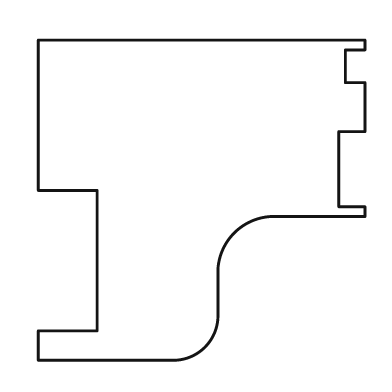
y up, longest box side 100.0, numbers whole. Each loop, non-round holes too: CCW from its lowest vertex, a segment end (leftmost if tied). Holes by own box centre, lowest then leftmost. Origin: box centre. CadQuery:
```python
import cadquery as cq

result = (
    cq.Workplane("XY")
    .moveTo(-50.0, -49.0)
    .lineTo(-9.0, -49.0)
    .threePointArc((1.0, -45.0), (5.0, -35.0))
    .lineTo(5.0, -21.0)
    .threePointArc((10.0, -10.0), (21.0, -5.0))
    .lineTo(50.0, -5.0)
    .lineTo(50.0, -2.0)
    .lineTo(42.0, -2.0)
    .lineTo(42.0, 21.0)
    .lineTo(50.0, 21.0)
    .lineTo(50.0, 36.0)
    .lineTo(44.0, 36.0)
    .lineTo(44.0, 46.0)
    .lineTo(50.0, 46.0)
    .lineTo(50.0, 49.0)
    .lineTo(-50.0, 49.0)
    .lineTo(-50.0, 3.0)
    .lineTo(-32.0, 3.0)
    .lineTo(-32.0, -40.0)
    .lineTo(-50.0, -40.0)
    .close()
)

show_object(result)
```